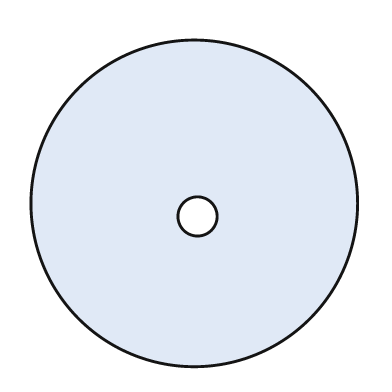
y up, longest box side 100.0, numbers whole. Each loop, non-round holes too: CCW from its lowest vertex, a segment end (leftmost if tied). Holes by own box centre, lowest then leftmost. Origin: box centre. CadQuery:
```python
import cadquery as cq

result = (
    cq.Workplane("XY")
    .moveTo(0.0, 0.0)
    .circle(50.0)
    .moveTo(1.0, -4.0)
    .circle(6.0)
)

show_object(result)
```